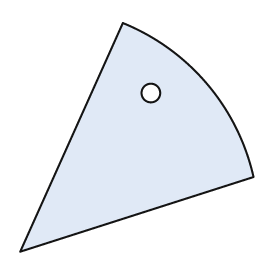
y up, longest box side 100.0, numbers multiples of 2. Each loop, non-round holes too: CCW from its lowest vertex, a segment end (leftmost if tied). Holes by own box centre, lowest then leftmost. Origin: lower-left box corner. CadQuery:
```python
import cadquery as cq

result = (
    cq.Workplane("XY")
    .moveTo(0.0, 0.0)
    .lineTo(100.0, 32.0)
    .threePointArc((80.0, 72.0), (44.0, 98.0))
    .close()
    .moveTo(56.0, 68.0)
    .circle(4.0)
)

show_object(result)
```